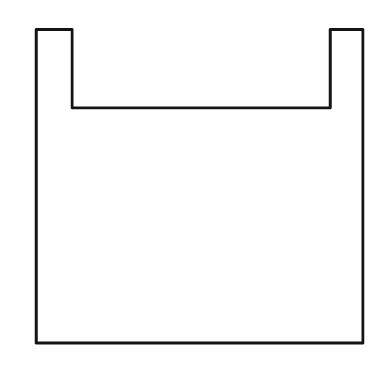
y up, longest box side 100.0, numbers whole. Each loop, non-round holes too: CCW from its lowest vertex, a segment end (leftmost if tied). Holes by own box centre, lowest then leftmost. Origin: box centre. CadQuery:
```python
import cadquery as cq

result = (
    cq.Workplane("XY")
    .moveTo(-50.0, -48.0)
    .lineTo(50.0, -48.0)
    .lineTo(50.0, 48.0)
    .lineTo(40.0, 48.0)
    .lineTo(40.0, 24.0)
    .lineTo(-39.0, 24.0)
    .lineTo(-39.0, 48.0)
    .lineTo(-50.0, 48.0)
    .close()
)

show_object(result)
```